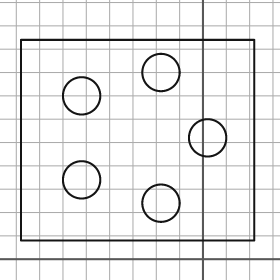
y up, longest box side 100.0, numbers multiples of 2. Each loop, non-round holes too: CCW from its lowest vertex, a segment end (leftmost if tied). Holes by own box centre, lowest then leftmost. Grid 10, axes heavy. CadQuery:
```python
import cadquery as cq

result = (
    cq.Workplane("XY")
    .moveTo(-78.0, 8.0)
    .lineTo(22.0, 8.0)
    .lineTo(22.0, 94.0)
    .lineTo(-78.0, 94.0)
    .close()
    .moveTo(-18.0, 24.0)
    .circle(8.0)
    .moveTo(-52.0, 34.0)
    .circle(8.0)
    .moveTo(2.0, 52.0)
    .circle(8.0)
    .moveTo(-52.0, 70.0)
    .circle(8.0)
    .moveTo(-18.0, 80.0)
    .circle(8.0)
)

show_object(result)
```